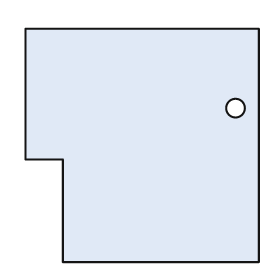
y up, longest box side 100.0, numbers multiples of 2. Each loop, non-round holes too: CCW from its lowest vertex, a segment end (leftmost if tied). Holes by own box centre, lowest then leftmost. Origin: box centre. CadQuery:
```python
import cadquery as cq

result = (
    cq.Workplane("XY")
    .moveTo(-34.0, -50.0)
    .lineTo(50.0, -50.0)
    .lineTo(50.0, 50.0)
    .lineTo(-50.0, 50.0)
    .lineTo(-50.0, -6.0)
    .lineTo(-34.0, -6.0)
    .close()
    .moveTo(40.0, 16.0)
    .circle(4.0)
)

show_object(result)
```